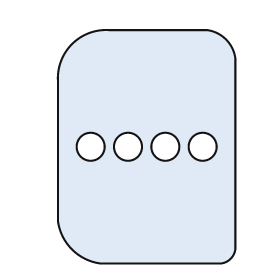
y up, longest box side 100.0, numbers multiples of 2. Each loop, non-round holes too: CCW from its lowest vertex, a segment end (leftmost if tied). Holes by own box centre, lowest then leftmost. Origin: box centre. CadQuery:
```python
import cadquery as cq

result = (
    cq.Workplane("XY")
    .moveTo(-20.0, -50.0)
    .lineTo(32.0, -50.0)
    .threePointArc((36.0, -48.0), (38.0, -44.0))
    .lineTo(38.0, 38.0)
    .threePointArc((34.0, 46.0), (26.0, 50.0))
    .lineTo(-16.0, 50.0)
    .threePointArc((-32.0, 44.0), (-38.0, 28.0))
    .lineTo(-38.0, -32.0)
    .threePointArc((-32.0, -44.0), (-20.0, -50.0))
    .close()
    .moveTo(-24.0, 0.0)
    .circle(6.0)
    .moveTo(-8.0, 0.0)
    .circle(6.0)
    .moveTo(8.0, 0.0)
    .circle(6.0)
    .moveTo(24.0, 0.0)
    .circle(6.0)
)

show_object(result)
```